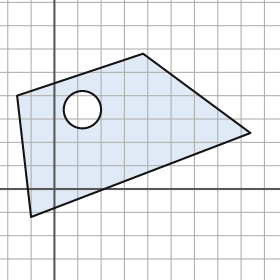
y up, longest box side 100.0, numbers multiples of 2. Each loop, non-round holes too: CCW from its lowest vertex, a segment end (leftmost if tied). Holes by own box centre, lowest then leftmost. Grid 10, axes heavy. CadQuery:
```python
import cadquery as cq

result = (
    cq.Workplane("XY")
    .moveTo(-10.0, -12.0)
    .lineTo(84.0, 24.0)
    .lineTo(38.0, 58.0)
    .lineTo(-16.0, 40.0)
    .close()
    .moveTo(12.0, 34.0)
    .circle(8.0)
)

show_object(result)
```